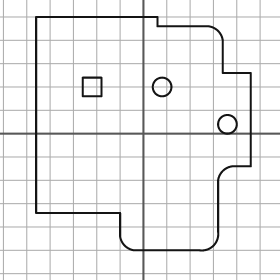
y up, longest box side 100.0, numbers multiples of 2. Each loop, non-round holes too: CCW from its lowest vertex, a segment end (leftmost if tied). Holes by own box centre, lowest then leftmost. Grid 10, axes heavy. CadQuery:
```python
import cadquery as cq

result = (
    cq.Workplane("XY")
    .moveTo(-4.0, -50.0)
    .lineTo(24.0, -50.0)
    .threePointArc((30.0, -48.0), (32.0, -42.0))
    .lineTo(32.0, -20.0)
    .threePointArc((34.0, -16.0), (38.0, -14.0))
    .lineTo(46.0, -14.0)
    .lineTo(46.0, 26.0)
    .lineTo(34.0, 26.0)
    .lineTo(34.0, 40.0)
    .threePointArc((32.0, 44.0), (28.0, 46.0))
    .lineTo(6.0, 46.0)
    .lineTo(6.0, 50.0)
    .lineTo(-46.0, 50.0)
    .lineTo(-46.0, -34.0)
    .lineTo(-10.0, -34.0)
    .lineTo(-10.0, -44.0)
    .threePointArc((-8.0, -48.0), (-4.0, -50.0))
    .close()
    .moveTo(36.0, 4.0)
    .circle(4.0)
    .moveTo(-26.0, 16.0)
    .lineTo(-18.0, 16.0)
    .lineTo(-18.0, 24.0)
    .lineTo(-26.0, 24.0)
    .close()
    .moveTo(8.0, 20.0)
    .circle(4.0)
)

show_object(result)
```